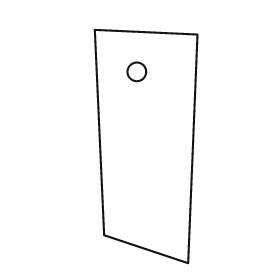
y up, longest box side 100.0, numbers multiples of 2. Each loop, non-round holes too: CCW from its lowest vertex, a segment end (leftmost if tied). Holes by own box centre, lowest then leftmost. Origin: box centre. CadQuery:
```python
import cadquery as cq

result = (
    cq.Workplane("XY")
    .moveTo(18.0, -50.0)
    .lineTo(22.0, 48.0)
    .lineTo(-22.0, 50.0)
    .lineTo(-18.0, -38.0)
    .close()
    .moveTo(-4.0, 32.0)
    .circle(4.0)
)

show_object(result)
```